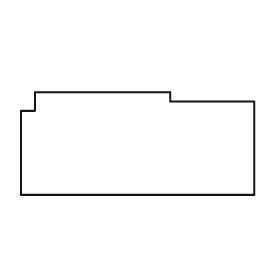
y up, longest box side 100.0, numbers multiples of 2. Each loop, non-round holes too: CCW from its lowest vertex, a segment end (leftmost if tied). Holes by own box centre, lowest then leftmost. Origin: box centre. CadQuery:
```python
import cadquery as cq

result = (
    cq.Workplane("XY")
    .moveTo(-50.0, -22.0)
    .lineTo(50.0, -22.0)
    .lineTo(50.0, 18.0)
    .lineTo(14.0, 18.0)
    .lineTo(14.0, 22.0)
    .lineTo(-44.0, 22.0)
    .lineTo(-44.0, 14.0)
    .lineTo(-50.0, 14.0)
    .close()
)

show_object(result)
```